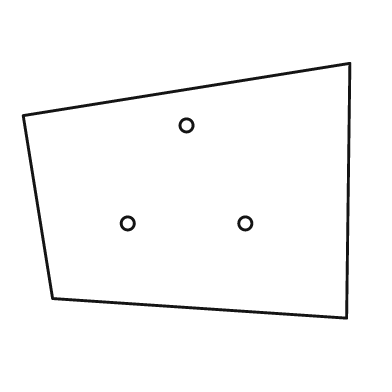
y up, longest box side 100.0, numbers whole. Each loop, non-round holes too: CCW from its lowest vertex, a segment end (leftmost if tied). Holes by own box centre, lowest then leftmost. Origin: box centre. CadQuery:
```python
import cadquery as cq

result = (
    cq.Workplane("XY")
    .moveTo(49.0, -39.0)
    .lineTo(50.0, 39.0)
    .lineTo(-50.0, 23.0)
    .lineTo(-41.0, -33.0)
    .close()
    .moveTo(-18.0, -10.0)
    .circle(2.0)
    .moveTo(18.0, -10.0)
    .circle(2.0)
    .moveTo(0.0, 20.0)
    .circle(2.0)
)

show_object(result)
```